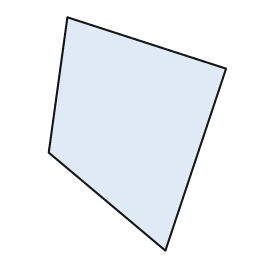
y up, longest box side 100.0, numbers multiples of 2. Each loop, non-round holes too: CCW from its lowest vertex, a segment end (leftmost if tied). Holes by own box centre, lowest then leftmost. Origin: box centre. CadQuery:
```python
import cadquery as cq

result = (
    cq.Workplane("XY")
    .moveTo(12.0, -50.0)
    .lineTo(38.0, 28.0)
    .lineTo(-30.0, 50.0)
    .lineTo(-38.0, -8.0)
    .close()
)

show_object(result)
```